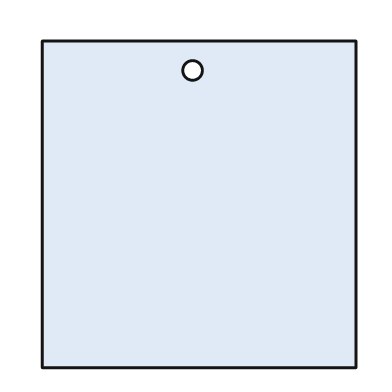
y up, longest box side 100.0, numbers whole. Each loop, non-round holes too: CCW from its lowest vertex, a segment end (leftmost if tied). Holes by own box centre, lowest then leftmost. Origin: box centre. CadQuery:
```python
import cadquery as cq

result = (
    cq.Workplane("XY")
    .moveTo(-48.0, -50.0)
    .lineTo(48.0, -50.0)
    .lineTo(48.0, 50.0)
    .lineTo(-48.0, 50.0)
    .close()
    .moveTo(-2.0, 41.0)
    .circle(3.0)
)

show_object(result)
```